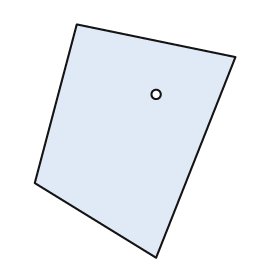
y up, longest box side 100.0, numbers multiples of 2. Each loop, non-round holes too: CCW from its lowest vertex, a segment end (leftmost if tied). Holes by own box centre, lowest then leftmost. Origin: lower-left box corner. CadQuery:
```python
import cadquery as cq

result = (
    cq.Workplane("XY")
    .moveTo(52.0, 0.0)
    .lineTo(86.0, 86.0)
    .lineTo(18.0, 100.0)
    .lineTo(0.0, 32.0)
    .close()
    .moveTo(52.0, 70.0)
    .circle(2.0)
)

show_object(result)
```